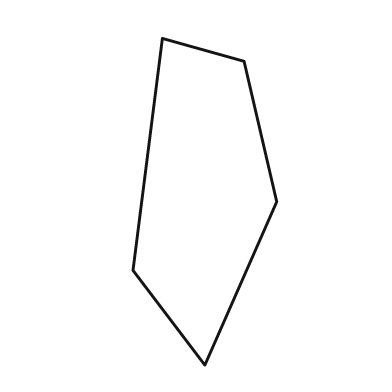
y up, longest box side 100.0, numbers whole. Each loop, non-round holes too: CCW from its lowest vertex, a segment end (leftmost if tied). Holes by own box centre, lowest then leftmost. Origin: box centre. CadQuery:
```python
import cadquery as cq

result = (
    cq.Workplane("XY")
    .moveTo(0.0, -50.0)
    .lineTo(22.0, 0.0)
    .lineTo(12.0, 43.0)
    .lineTo(-13.0, 50.0)
    .lineTo(-22.0, -21.0)
    .close()
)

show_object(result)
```